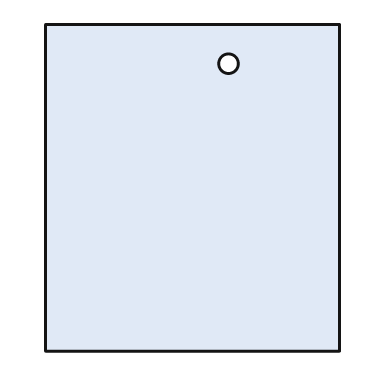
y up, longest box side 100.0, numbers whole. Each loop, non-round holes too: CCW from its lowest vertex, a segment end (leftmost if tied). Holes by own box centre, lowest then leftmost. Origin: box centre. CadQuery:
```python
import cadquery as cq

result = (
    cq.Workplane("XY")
    .moveTo(-45.0, -50.0)
    .lineTo(45.0, -50.0)
    .lineTo(45.0, 50.0)
    .lineTo(-45.0, 50.0)
    .close()
    .moveTo(11.0, 38.0)
    .circle(3.0)
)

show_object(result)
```